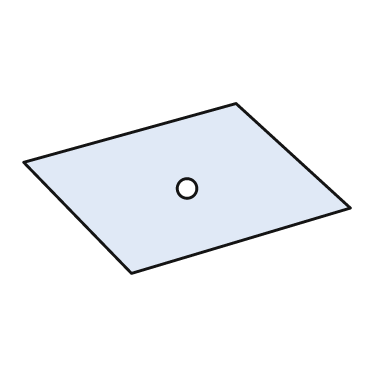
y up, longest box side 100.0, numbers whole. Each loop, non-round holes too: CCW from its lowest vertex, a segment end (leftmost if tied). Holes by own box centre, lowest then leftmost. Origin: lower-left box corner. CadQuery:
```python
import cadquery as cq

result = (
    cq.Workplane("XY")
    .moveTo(33.0, 0.0)
    .lineTo(100.0, 20.0)
    .lineTo(65.0, 52.0)
    .lineTo(0.0, 34.0)
    .close()
    .moveTo(50.0, 26.0)
    .circle(3.0)
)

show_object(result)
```